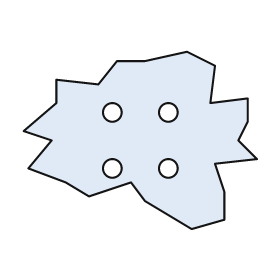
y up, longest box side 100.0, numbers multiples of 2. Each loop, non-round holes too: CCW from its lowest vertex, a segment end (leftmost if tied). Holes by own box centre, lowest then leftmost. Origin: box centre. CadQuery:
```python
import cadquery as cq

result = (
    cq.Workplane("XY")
    .moveTo(22.0, -38.0)
    .lineTo(36.0, -34.0)
    .lineTo(36.0, -22.0)
    .lineTo(32.0, -10.0)
    .lineTo(50.0, -8.0)
    .lineTo(42.0, 0.0)
    .lineTo(46.0, 8.0)
    .lineTo(46.0, 18.0)
    .lineTo(30.0, 16.0)
    .lineTo(32.0, 32.0)
    .lineTo(20.0, 38.0)
    .lineTo(2.0, 34.0)
    .lineTo(-10.0, 34.0)
    .lineTo(-18.0, 24.0)
    .lineTo(-36.0, 26.0)
    .lineTo(-36.0, 16.0)
    .lineTo(-50.0, 4.0)
    .lineTo(-38.0, 0.0)
    .lineTo(-48.0, -12.0)
    .lineTo(-32.0, -18.0)
    .lineTo(-22.0, -24.0)
    .lineTo(-4.0, -18.0)
    .lineTo(2.0, -26.0)
    .close()
    .moveTo(-12.0, -12.0)
    .circle(4.0)
    .moveTo(12.0, -12.0)
    .circle(4.0)
    .moveTo(-12.0, 12.0)
    .circle(4.0)
    .moveTo(12.0, 12.0)
    .circle(4.0)
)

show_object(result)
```